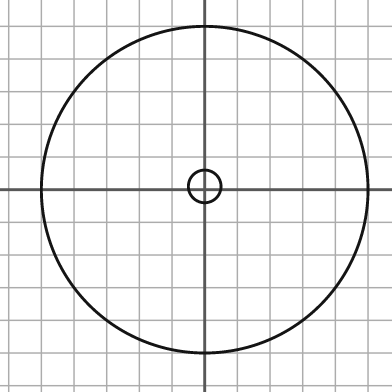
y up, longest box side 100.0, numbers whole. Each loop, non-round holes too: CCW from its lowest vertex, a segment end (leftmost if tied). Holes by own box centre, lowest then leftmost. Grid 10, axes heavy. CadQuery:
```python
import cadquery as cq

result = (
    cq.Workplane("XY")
    .moveTo(0.0, 0.0)
    .circle(50.0)
    .moveTo(0.0, 1.0)
    .circle(5.0)
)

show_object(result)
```